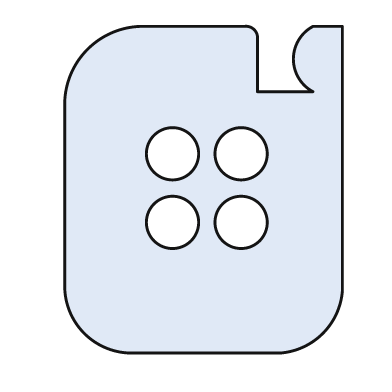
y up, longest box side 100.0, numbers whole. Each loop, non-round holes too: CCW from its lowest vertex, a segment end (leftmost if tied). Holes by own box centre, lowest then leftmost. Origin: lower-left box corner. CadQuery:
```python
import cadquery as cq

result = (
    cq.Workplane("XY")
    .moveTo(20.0, 0.0)
    .lineTo(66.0, 0.0)
    .threePointArc((79.0, 6.0), (85.0, 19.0))
    .lineTo(85.0, 100.0)
    .lineTo(76.0, 100.0)
    .threePointArc((70.0, 90.0), (76.0, 80.0))
    .lineTo(59.0, 80.0)
    .lineTo(59.0, 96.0)
    .threePointArc((58.0, 99.0), (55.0, 100.0))
    .lineTo(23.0, 100.0)
    .threePointArc((7.0, 93.0), (0.0, 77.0))
    .lineTo(0.0, 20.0)
    .threePointArc((6.0, 6.0), (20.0, 0.0))
    .close()
    .moveTo(33.0, 40.0)
    .circle(8.0)
    .moveTo(54.0, 40.0)
    .circle(8.0)
    .moveTo(33.0, 61.0)
    .circle(8.0)
    .moveTo(54.0, 61.0)
    .circle(8.0)
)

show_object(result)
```